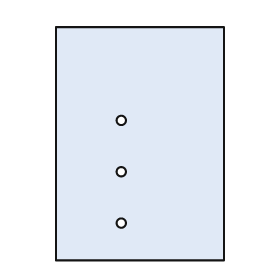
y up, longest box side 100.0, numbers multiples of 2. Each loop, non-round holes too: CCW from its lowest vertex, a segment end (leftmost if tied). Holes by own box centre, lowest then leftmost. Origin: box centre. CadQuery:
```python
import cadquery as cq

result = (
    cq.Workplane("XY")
    .moveTo(-36.0, -50.0)
    .lineTo(36.0, -50.0)
    .lineTo(36.0, 50.0)
    .lineTo(-36.0, 50.0)
    .close()
    .moveTo(-8.0, -34.0)
    .circle(2.0)
    .moveTo(-8.0, -12.0)
    .circle(2.0)
    .moveTo(-8.0, 10.0)
    .circle(2.0)
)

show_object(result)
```